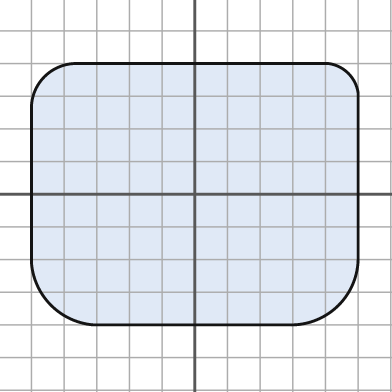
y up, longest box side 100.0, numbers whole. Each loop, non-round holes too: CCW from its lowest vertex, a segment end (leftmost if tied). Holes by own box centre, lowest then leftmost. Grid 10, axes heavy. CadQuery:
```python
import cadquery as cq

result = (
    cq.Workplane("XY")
    .moveTo(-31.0, -40.0)
    .lineTo(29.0, -40.0)
    .threePointArc((44.0, -34.0), (50.0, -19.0))
    .lineTo(50.0, 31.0)
    .threePointArc((47.0, 37.0), (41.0, 40.0))
    .lineTo(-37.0, 40.0)
    .threePointArc((-46.0, 36.0), (-50.0, 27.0))
    .lineTo(-50.0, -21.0)
    .threePointArc((-44.0, -34.0), (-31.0, -40.0))
    .close()
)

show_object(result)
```